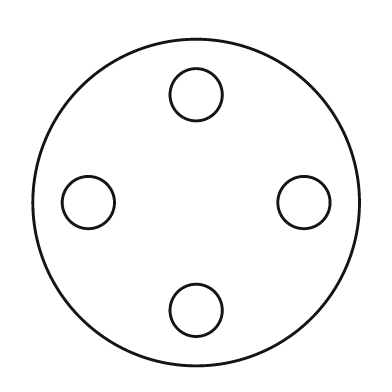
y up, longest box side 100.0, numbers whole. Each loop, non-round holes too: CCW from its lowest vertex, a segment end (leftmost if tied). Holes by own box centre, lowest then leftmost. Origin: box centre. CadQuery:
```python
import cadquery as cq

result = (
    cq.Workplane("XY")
    .moveTo(0.0, 0.0)
    .circle(50.0)
    .moveTo(0.0, -33.0)
    .circle(8.0)
    .moveTo(-33.0, 0.0)
    .circle(8.0)
    .moveTo(33.0, 0.0)
    .circle(8.0)
    .moveTo(0.0, 33.0)
    .circle(8.0)
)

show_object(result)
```